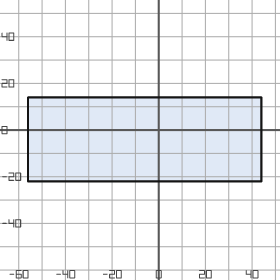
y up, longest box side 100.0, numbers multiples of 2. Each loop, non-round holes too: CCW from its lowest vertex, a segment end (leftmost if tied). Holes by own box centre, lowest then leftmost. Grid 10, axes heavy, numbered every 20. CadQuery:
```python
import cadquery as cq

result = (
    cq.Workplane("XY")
    .moveTo(-56.0, -22.0)
    .lineTo(44.0, -22.0)
    .lineTo(44.0, 14.0)
    .lineTo(-56.0, 14.0)
    .close()
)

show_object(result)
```